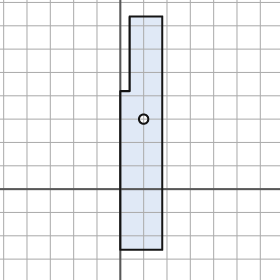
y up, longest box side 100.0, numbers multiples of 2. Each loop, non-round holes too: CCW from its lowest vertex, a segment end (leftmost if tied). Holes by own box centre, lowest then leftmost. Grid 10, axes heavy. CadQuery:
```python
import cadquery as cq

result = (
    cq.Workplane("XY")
    .moveTo(0.0, -26.0)
    .lineTo(18.0, -26.0)
    .lineTo(18.0, 74.0)
    .lineTo(4.0, 74.0)
    .lineTo(4.0, 42.0)
    .lineTo(0.0, 42.0)
    .close()
    .moveTo(10.0, 30.0)
    .circle(2.0)
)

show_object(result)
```